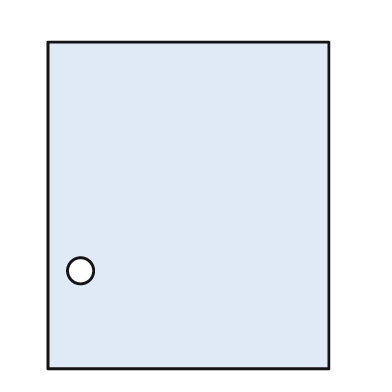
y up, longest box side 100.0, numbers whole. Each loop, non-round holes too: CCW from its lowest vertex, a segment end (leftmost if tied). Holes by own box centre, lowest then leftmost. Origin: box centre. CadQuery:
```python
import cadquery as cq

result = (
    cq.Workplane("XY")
    .moveTo(-43.0, -50.0)
    .lineTo(43.0, -50.0)
    .lineTo(43.0, 50.0)
    .lineTo(-43.0, 50.0)
    .close()
    .moveTo(-33.0, -20.0)
    .circle(4.0)
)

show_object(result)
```